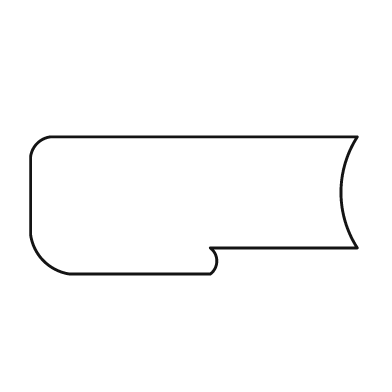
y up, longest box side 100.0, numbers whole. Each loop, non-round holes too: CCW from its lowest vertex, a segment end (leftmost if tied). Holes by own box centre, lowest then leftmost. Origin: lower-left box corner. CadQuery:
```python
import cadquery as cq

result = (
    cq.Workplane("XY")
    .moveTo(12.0, 0.0)
    .lineTo(55.0, 0.0)
    .threePointArc((57.0, 4.0), (55.0, 8.0))
    .lineTo(100.0, 8.0)
    .threePointArc((95.0, 25.0), (100.0, 42.0))
    .lineTo(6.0, 42.0)
    .threePointArc((2.0, 40.0), (0.0, 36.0))
    .lineTo(0.0, 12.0)
    .threePointArc((4.0, 4.0), (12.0, 0.0))
    .close()
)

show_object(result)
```